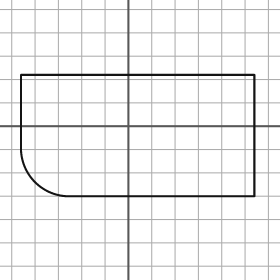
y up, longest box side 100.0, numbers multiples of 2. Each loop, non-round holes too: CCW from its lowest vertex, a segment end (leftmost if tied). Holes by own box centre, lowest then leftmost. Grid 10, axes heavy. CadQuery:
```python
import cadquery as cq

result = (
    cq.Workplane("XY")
    .moveTo(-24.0, -30.0)
    .lineTo(54.0, -30.0)
    .lineTo(54.0, 22.0)
    .lineTo(-46.0, 22.0)
    .lineTo(-46.0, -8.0)
    .threePointArc((-40.0, -24.0), (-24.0, -30.0))
    .close()
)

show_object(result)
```